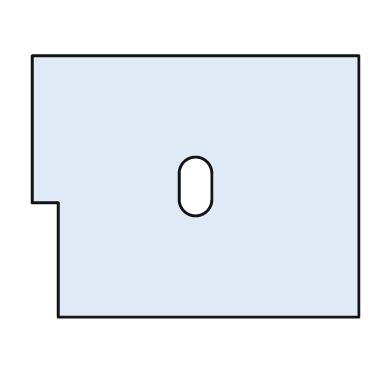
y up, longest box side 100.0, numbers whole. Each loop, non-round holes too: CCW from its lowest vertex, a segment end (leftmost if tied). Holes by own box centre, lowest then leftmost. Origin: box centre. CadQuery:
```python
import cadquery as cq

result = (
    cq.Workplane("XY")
    .moveTo(-42.0, -40.0)
    .lineTo(50.0, -40.0)
    .lineTo(50.0, 40.0)
    .lineTo(-50.0, 40.0)
    .lineTo(-50.0, -5.0)
    .lineTo(-42.0, -5.0)
    .close()
    .moveTo(-5.0, -4.0)
    .threePointArc((0.0, -9.0), (5.0, -4.0))
    .lineTo(5.0, 4.0)
    .threePointArc((0.0, 9.0), (-5.0, 4.0))
    .close()
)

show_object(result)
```